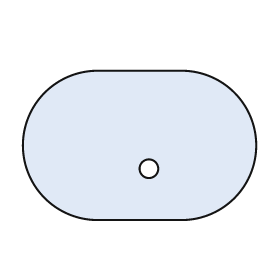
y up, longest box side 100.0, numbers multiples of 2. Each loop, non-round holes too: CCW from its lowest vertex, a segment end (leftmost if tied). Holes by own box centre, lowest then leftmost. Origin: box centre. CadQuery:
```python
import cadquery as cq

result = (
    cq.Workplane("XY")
    .moveTo(-18.0, -32.0)
    .lineTo(18.0, -32.0)
    .threePointArc((50.0, 0.0), (18.0, 32.0))
    .lineTo(-18.0, 32.0)
    .threePointArc((-50.0, 0.0), (-18.0, -32.0))
    .close()
    .moveTo(4.0, -10.0)
    .circle(4.0)
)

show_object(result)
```